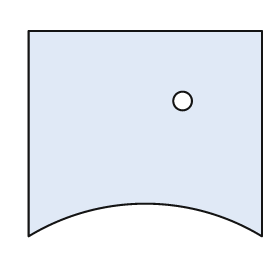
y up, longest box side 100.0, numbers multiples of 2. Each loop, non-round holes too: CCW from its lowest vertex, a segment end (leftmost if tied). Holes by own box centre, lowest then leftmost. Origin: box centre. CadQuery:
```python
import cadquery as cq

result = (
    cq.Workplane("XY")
    .moveTo(-50.0, -44.0)
    .threePointArc((0.0, -30.0), (50.0, -44.0))
    .lineTo(50.0, 44.0)
    .lineTo(-50.0, 44.0)
    .close()
    .moveTo(16.0, 14.0)
    .circle(4.0)
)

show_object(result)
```